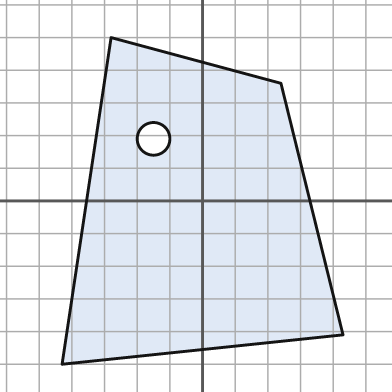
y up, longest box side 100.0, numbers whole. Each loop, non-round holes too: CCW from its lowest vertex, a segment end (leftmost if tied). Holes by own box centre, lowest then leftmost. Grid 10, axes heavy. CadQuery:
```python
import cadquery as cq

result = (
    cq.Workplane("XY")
    .moveTo(-43.0, -50.0)
    .lineTo(43.0, -41.0)
    .lineTo(24.0, 36.0)
    .lineTo(-28.0, 50.0)
    .close()
    .moveTo(-15.0, 19.0)
    .circle(5.0)
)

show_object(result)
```